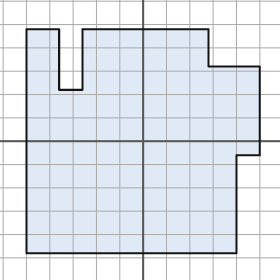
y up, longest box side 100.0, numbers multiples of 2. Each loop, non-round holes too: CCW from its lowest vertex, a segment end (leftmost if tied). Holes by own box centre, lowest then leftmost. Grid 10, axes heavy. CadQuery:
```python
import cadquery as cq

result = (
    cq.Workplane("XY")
    .moveTo(-50.0, -48.0)
    .lineTo(40.0, -48.0)
    .lineTo(40.0, -6.0)
    .lineTo(50.0, -6.0)
    .lineTo(50.0, 32.0)
    .lineTo(28.0, 32.0)
    .lineTo(28.0, 48.0)
    .lineTo(-26.0, 48.0)
    .lineTo(-26.0, 22.0)
    .lineTo(-36.0, 22.0)
    .lineTo(-36.0, 48.0)
    .lineTo(-50.0, 48.0)
    .close()
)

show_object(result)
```